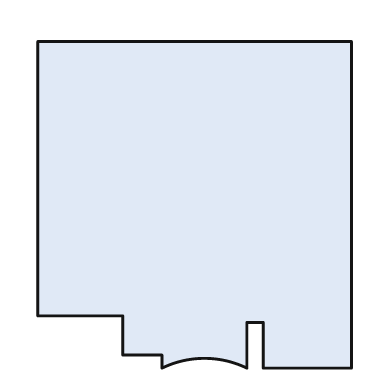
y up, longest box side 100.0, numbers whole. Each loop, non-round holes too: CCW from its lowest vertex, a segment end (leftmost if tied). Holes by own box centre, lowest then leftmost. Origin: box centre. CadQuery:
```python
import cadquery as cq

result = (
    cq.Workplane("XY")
    .moveTo(-10.0, -50.0)
    .threePointArc((3.0, -47.0), (16.0, -50.0))
    .lineTo(16.0, -36.0)
    .lineTo(21.0, -36.0)
    .lineTo(21.0, -50.0)
    .lineTo(48.0, -50.0)
    .lineTo(48.0, 50.0)
    .lineTo(-48.0, 50.0)
    .lineTo(-48.0, -34.0)
    .lineTo(-22.0, -34.0)
    .lineTo(-22.0, -46.0)
    .lineTo(-10.0, -46.0)
    .close()
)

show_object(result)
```